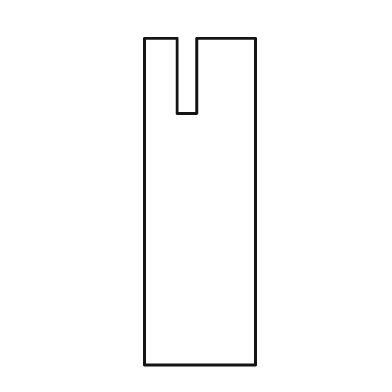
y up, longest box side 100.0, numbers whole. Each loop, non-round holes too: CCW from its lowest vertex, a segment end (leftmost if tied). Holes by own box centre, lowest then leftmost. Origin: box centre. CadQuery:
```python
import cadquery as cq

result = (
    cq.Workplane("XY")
    .moveTo(-17.0, -50.0)
    .lineTo(17.0, -50.0)
    .lineTo(17.0, 50.0)
    .lineTo(-1.0, 50.0)
    .lineTo(-1.0, 27.0)
    .lineTo(-7.0, 27.0)
    .lineTo(-7.0, 50.0)
    .lineTo(-17.0, 50.0)
    .close()
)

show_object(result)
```